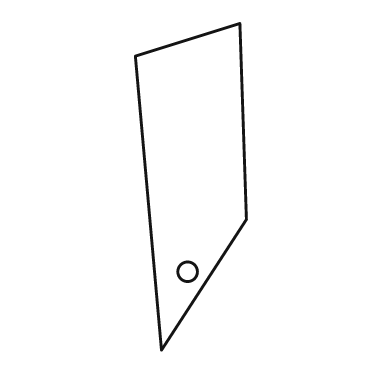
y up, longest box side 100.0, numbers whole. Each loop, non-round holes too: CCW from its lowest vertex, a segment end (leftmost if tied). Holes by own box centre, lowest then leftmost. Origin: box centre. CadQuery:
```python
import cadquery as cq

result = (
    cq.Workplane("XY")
    .moveTo(-9.0, -50.0)
    .lineTo(17.0, -10.0)
    .lineTo(15.0, 50.0)
    .lineTo(-17.0, 40.0)
    .close()
    .moveTo(-1.0, -26.0)
    .circle(3.0)
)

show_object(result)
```